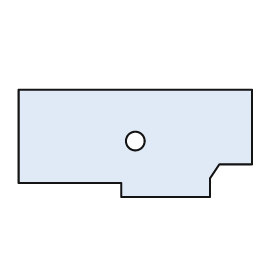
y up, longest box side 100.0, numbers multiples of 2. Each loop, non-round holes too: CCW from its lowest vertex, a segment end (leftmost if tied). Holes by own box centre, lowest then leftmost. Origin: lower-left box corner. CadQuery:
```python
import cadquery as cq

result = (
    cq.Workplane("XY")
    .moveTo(44.0, 0.0)
    .lineTo(82.0, 0.0)
    .lineTo(82.0, 8.0)
    .lineTo(86.0, 14.0)
    .lineTo(100.0, 14.0)
    .lineTo(100.0, 46.0)
    .lineTo(0.0, 46.0)
    .lineTo(0.0, 6.0)
    .lineTo(44.0, 6.0)
    .close()
    .moveTo(50.0, 24.0)
    .circle(4.0)
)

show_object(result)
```